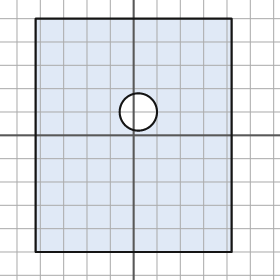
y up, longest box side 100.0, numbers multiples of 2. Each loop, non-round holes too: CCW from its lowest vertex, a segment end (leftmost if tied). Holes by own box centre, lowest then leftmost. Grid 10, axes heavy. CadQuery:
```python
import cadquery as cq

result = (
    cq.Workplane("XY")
    .moveTo(-42.0, -50.0)
    .lineTo(42.0, -50.0)
    .lineTo(42.0, 50.0)
    .lineTo(-42.0, 50.0)
    .close()
    .moveTo(2.0, 10.0)
    .circle(8.0)
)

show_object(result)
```